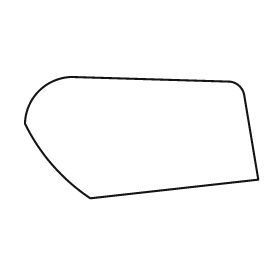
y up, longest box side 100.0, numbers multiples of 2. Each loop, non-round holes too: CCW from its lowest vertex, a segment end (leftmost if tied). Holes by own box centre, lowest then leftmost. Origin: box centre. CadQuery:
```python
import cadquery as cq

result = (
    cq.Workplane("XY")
    .moveTo(-22.0, -26.0)
    .lineTo(50.0, -18.0)
    .lineTo(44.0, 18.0)
    .threePointArc((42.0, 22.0), (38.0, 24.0))
    .lineTo(-30.0, 26.0)
    .threePointArc((-44.0, 20.0), (-50.0, 6.0))
    .threePointArc((-38.0, -12.0), (-22.0, -26.0))
    .close()
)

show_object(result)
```